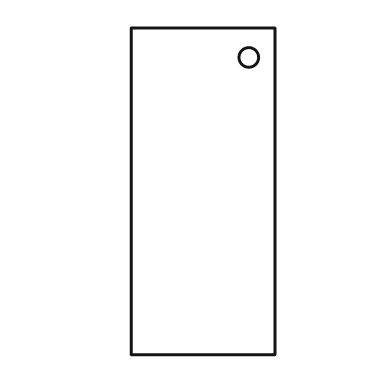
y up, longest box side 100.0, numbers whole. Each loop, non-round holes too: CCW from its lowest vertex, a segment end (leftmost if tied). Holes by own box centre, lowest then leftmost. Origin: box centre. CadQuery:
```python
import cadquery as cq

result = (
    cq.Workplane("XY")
    .moveTo(-22.0, -50.0)
    .lineTo(22.0, -50.0)
    .lineTo(22.0, 50.0)
    .lineTo(-22.0, 50.0)
    .close()
    .moveTo(14.0, 41.0)
    .circle(3.0)
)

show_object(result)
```